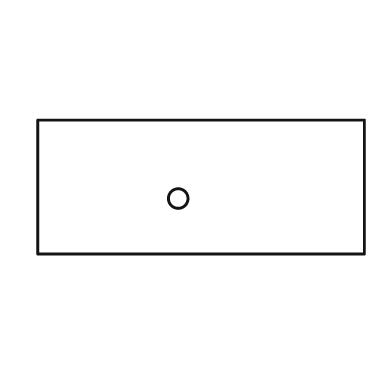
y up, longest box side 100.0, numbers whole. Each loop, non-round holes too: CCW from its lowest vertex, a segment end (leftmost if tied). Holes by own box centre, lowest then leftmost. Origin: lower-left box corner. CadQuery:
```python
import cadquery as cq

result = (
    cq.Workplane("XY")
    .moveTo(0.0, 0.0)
    .lineTo(100.0, 0.0)
    .lineTo(100.0, 41.0)
    .lineTo(0.0, 41.0)
    .close()
    .moveTo(43.0, 17.0)
    .circle(3.0)
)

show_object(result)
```